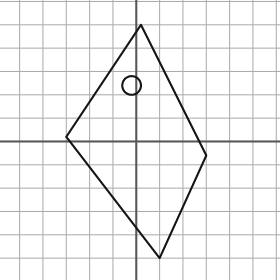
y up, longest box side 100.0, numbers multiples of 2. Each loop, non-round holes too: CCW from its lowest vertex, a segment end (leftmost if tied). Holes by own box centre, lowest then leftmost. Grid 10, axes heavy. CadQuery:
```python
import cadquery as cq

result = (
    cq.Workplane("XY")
    .moveTo(10.0, -50.0)
    .lineTo(30.0, -6.0)
    .lineTo(2.0, 50.0)
    .lineTo(-30.0, 2.0)
    .close()
    .moveTo(-2.0, 24.0)
    .circle(4.0)
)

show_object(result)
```